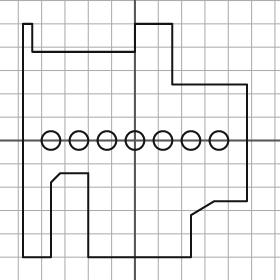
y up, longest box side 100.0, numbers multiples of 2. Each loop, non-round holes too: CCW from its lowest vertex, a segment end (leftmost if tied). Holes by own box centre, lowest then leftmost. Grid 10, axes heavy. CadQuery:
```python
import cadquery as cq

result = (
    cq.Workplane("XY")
    .moveTo(-48.0, -50.0)
    .lineTo(-36.0, -50.0)
    .lineTo(-36.0, -18.0)
    .lineTo(-32.0, -14.0)
    .lineTo(-20.0, -14.0)
    .lineTo(-20.0, -50.0)
    .lineTo(24.0, -50.0)
    .lineTo(24.0, -32.0)
    .lineTo(34.0, -26.0)
    .lineTo(48.0, -26.0)
    .lineTo(48.0, 24.0)
    .lineTo(16.0, 24.0)
    .lineTo(16.0, 50.0)
    .lineTo(0.0, 50.0)
    .lineTo(0.0, 38.0)
    .lineTo(-44.0, 38.0)
    .lineTo(-44.0, 50.0)
    .lineTo(-48.0, 50.0)
    .close()
    .moveTo(-36.0, 0.0)
    .circle(4.0)
    .moveTo(-24.0, 0.0)
    .circle(4.0)
    .moveTo(-12.0, 0.0)
    .circle(4.0)
    .moveTo(0.0, 0.0)
    .circle(4.0)
    .moveTo(12.0, 0.0)
    .circle(4.0)
    .moveTo(24.0, 0.0)
    .circle(4.0)
    .moveTo(36.0, 0.0)
    .circle(4.0)
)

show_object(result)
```